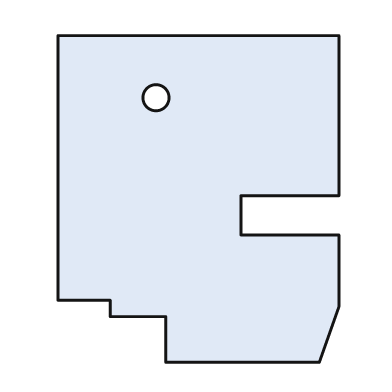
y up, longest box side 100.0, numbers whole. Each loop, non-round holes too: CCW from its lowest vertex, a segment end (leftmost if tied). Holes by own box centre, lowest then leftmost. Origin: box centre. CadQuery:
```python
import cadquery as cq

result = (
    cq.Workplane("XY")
    .moveTo(-10.0, -50.0)
    .lineTo(37.0, -50.0)
    .lineTo(43.0, -33.0)
    .lineTo(43.0, -11.0)
    .lineTo(13.0, -11.0)
    .lineTo(13.0, 1.0)
    .lineTo(43.0, 1.0)
    .lineTo(43.0, 50.0)
    .lineTo(-43.0, 50.0)
    .lineTo(-43.0, -31.0)
    .lineTo(-27.0, -31.0)
    .lineTo(-27.0, -36.0)
    .lineTo(-10.0, -36.0)
    .close()
    .moveTo(-13.0, 31.0)
    .circle(4.0)
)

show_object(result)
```